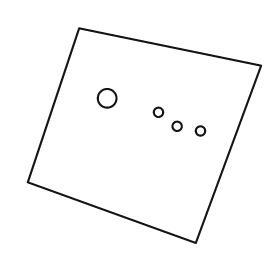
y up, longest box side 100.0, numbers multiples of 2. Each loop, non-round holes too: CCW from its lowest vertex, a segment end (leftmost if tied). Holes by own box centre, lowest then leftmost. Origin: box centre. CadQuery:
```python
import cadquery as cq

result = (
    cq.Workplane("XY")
    .moveTo(22.0, -46.0)
    .lineTo(50.0, 30.0)
    .lineTo(-28.0, 46.0)
    .lineTo(-50.0, -20.0)
    .close()
    .moveTo(24.0, 2.0)
    .circle(2.0)
    .moveTo(14.0, 4.0)
    .circle(2.0)
    .moveTo(6.0, 10.0)
    .circle(2.0)
    .moveTo(-16.0, 16.0)
    .circle(4.0)
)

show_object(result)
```